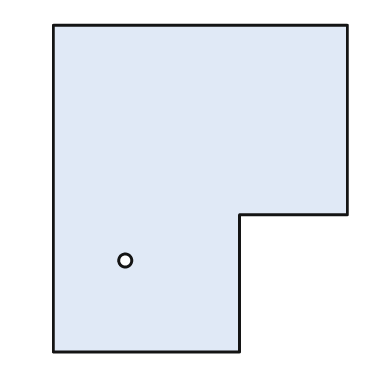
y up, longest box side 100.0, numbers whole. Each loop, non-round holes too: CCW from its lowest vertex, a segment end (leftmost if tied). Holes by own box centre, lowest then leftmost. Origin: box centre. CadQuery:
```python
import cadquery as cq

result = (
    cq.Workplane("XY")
    .moveTo(-45.0, -50.0)
    .lineTo(12.0, -50.0)
    .lineTo(12.0, -8.0)
    .lineTo(45.0, -8.0)
    .lineTo(45.0, 50.0)
    .lineTo(-45.0, 50.0)
    .close()
    .moveTo(-23.0, -22.0)
    .circle(2.0)
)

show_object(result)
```